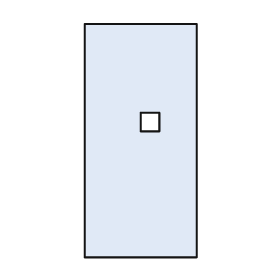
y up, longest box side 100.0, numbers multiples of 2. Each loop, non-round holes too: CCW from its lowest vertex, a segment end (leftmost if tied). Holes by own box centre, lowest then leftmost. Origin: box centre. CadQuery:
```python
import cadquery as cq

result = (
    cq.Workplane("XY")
    .moveTo(-24.0, -50.0)
    .lineTo(24.0, -50.0)
    .lineTo(24.0, 50.0)
    .lineTo(-24.0, 50.0)
    .close()
    .moveTo(0.0, 4.0)
    .lineTo(8.0, 4.0)
    .lineTo(8.0, 12.0)
    .lineTo(0.0, 12.0)
    .close()
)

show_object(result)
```